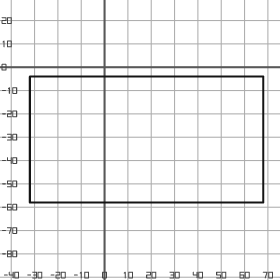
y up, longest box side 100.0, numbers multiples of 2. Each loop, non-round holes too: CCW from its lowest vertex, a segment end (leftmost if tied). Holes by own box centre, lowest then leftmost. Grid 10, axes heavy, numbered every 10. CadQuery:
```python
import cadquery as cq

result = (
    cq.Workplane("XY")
    .moveTo(-32.0, -58.0)
    .lineTo(68.0, -58.0)
    .lineTo(68.0, -4.0)
    .lineTo(-32.0, -4.0)
    .close()
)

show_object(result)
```